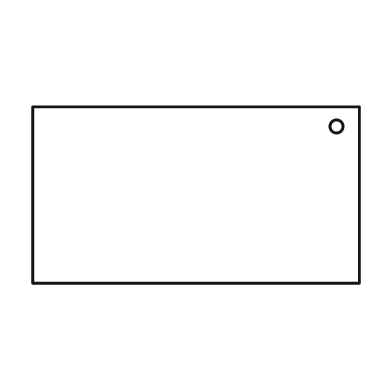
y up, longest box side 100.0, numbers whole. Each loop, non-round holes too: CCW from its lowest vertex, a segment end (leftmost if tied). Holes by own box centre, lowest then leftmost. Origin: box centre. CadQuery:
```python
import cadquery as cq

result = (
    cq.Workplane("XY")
    .moveTo(-50.0, -27.0)
    .lineTo(50.0, -27.0)
    .lineTo(50.0, 27.0)
    .lineTo(-50.0, 27.0)
    .close()
    .moveTo(43.0, 21.0)
    .circle(2.0)
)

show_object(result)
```